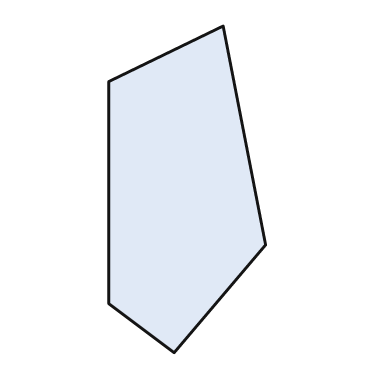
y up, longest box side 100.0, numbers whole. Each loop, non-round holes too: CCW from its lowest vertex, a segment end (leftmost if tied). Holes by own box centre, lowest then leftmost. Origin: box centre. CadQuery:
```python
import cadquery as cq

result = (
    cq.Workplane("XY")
    .moveTo(-4.0, -50.0)
    .lineTo(24.0, -17.0)
    .lineTo(11.0, 50.0)
    .lineTo(-24.0, 33.0)
    .lineTo(-24.0, -35.0)
    .close()
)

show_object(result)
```